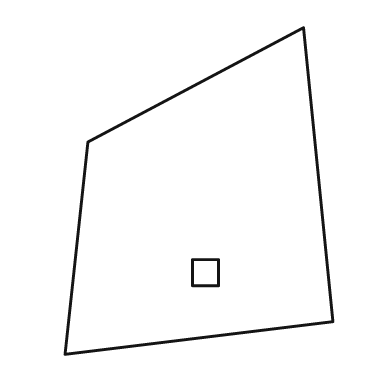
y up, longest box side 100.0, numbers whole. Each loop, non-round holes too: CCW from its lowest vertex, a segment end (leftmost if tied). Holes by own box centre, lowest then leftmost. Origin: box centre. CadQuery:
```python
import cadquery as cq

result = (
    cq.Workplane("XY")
    .moveTo(-41.0, -50.0)
    .lineTo(41.0, -40.0)
    .lineTo(32.0, 50.0)
    .lineTo(-34.0, 15.0)
    .close()
    .moveTo(-2.0, -29.0)
    .lineTo(6.0, -29.0)
    .lineTo(6.0, -21.0)
    .lineTo(-2.0, -21.0)
    .close()
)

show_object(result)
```